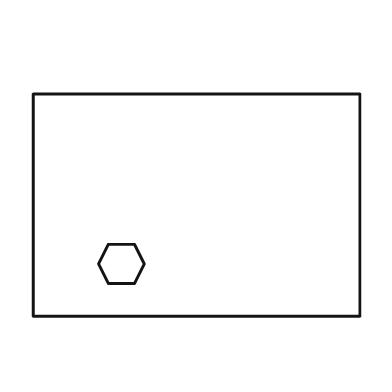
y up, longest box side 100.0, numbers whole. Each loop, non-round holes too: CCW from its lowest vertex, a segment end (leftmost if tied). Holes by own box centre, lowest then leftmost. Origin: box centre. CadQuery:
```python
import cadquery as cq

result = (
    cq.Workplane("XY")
    .moveTo(-50.0, -34.0)
    .lineTo(50.0, -34.0)
    .lineTo(50.0, 34.0)
    .lineTo(-50.0, 34.0)
    .close()
    .moveTo(-27.0, -24.0)
    .lineTo(-19.0, -24.0)
    .lineTo(-16.0, -18.0)
    .lineTo(-19.0, -12.0)
    .lineTo(-27.0, -12.0)
    .lineTo(-30.0, -18.0)
    .close()
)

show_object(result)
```